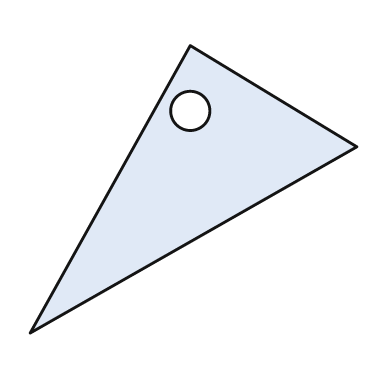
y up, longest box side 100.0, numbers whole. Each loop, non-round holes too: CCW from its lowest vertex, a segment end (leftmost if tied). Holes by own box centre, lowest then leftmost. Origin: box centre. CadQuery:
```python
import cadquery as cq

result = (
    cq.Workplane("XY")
    .moveTo(-50.0, -44.0)
    .lineTo(50.0, 13.0)
    .lineTo(-1.0, 44.0)
    .close()
    .moveTo(-1.0, 24.0)
    .circle(6.0)
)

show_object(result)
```